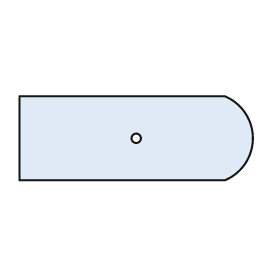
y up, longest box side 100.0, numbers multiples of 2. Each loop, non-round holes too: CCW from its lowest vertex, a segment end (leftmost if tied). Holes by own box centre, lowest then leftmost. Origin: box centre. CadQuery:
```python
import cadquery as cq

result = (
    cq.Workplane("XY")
    .moveTo(-50.0, -18.0)
    .lineTo(38.0, -18.0)
    .threePointArc((50.0, 0.0), (38.0, 18.0))
    .lineTo(-50.0, 18.0)
    .close()
    .moveTo(0.0, 0.0)
    .circle(2.0)
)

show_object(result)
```